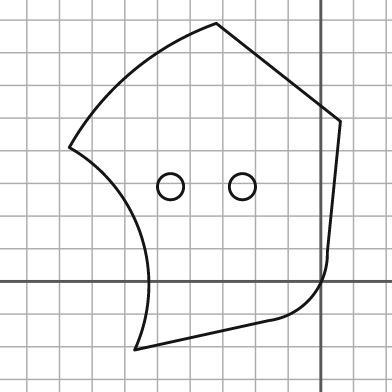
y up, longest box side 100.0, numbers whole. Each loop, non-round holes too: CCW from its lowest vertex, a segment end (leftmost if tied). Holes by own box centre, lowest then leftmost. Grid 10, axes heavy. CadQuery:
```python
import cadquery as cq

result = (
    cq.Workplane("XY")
    .moveTo(-57.0, -21.0)
    .lineTo(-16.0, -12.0)
    .threePointArc((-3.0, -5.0), (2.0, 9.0))
    .lineTo(6.0, 49.0)
    .lineTo(-32.0, 79.0)
    .threePointArc((-58.0, 64.0), (-77.0, 41.0))
    .threePointArc((-55.0, 14.0), (-57.0, -21.0))
    .close()
    .moveTo(-46.0, 29.0)
    .circle(4.0)
    .moveTo(-24.0, 29.0)
    .circle(4.0)
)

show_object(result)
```